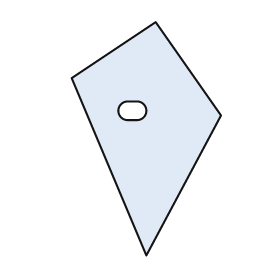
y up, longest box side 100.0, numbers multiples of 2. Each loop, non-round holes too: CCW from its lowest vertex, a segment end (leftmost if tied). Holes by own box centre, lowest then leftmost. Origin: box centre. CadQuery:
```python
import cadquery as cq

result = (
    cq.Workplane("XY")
    .moveTo(0.0, -50.0)
    .lineTo(32.0, 10.0)
    .lineTo(4.0, 50.0)
    .lineTo(-32.0, 26.0)
    .close()
    .moveTo(-8.0, 8.0)
    .lineTo(-4.0, 8.0)
    .threePointArc((0.0, 12.0), (-4.0, 16.0))
    .lineTo(-8.0, 16.0)
    .threePointArc((-12.0, 12.0), (-8.0, 8.0))
    .close()
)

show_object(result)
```